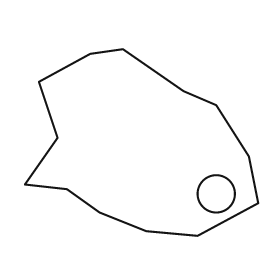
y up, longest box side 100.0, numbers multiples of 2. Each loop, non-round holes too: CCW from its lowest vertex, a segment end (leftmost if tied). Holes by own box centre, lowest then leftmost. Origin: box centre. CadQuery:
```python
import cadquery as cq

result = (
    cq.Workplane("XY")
    .moveTo(24.0, -40.0)
    .lineTo(50.0, -26.0)
    .lineTo(46.0, -6.0)
    .lineTo(32.0, 16.0)
    .lineTo(18.0, 22.0)
    .lineTo(-8.0, 40.0)
    .lineTo(-22.0, 38.0)
    .lineTo(-44.0, 26.0)
    .lineTo(-36.0, 2.0)
    .lineTo(-50.0, -18.0)
    .lineTo(-32.0, -20.0)
    .lineTo(-18.0, -30.0)
    .lineTo(2.0, -38.0)
    .close()
    .moveTo(32.0, -22.0)
    .circle(8.0)
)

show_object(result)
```